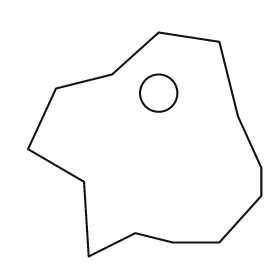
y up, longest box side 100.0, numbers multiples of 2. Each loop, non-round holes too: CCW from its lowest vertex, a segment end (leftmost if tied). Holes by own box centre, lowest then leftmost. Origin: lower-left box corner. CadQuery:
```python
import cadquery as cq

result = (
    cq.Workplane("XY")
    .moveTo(26.0, 0.0)
    .lineTo(46.0, 10.0)
    .lineTo(62.0, 6.0)
    .lineTo(82.0, 6.0)
    .lineTo(100.0, 26.0)
    .lineTo(100.0, 38.0)
    .lineTo(90.0, 60.0)
    .lineTo(82.0, 92.0)
    .lineTo(56.0, 96.0)
    .lineTo(36.0, 78.0)
    .lineTo(12.0, 72.0)
    .lineTo(0.0, 46.0)
    .lineTo(24.0, 32.0)
    .close()
    .moveTo(56.0, 70.0)
    .circle(8.0)
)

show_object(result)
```